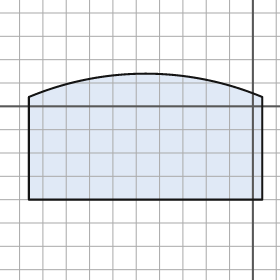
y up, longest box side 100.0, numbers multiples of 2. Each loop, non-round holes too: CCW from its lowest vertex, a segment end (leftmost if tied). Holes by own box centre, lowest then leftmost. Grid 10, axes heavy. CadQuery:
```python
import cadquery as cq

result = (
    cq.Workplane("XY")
    .moveTo(-96.0, -40.0)
    .lineTo(4.0, -40.0)
    .lineTo(4.0, 4.0)
    .threePointArc((-46.0, 14.0), (-96.0, 4.0))
    .close()
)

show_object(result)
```